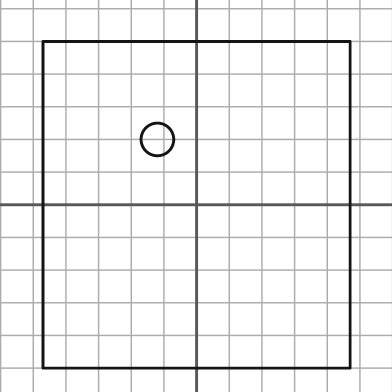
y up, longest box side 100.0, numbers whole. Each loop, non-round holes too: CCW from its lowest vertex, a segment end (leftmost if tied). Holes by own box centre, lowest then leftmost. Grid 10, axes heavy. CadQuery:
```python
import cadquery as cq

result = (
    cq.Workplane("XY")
    .moveTo(-47.0, -50.0)
    .lineTo(47.0, -50.0)
    .lineTo(47.0, 50.0)
    .lineTo(-47.0, 50.0)
    .close()
    .moveTo(-12.0, 20.0)
    .circle(5.0)
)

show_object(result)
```